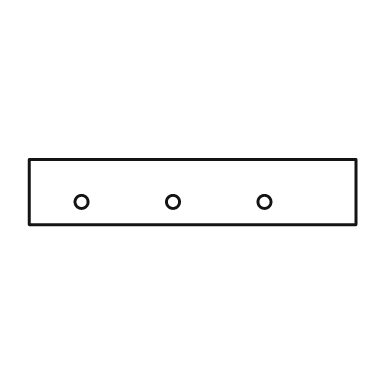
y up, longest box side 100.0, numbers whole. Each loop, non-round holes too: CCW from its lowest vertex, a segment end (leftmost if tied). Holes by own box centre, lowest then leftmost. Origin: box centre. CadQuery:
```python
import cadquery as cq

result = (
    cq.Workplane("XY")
    .moveTo(-50.0, -10.0)
    .lineTo(50.0, -10.0)
    .lineTo(50.0, 10.0)
    .lineTo(-50.0, 10.0)
    .close()
    .moveTo(-34.0, -3.0)
    .circle(2.0)
    .moveTo(-6.0, -3.0)
    .circle(2.0)
    .moveTo(22.0, -3.0)
    .circle(2.0)
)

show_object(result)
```